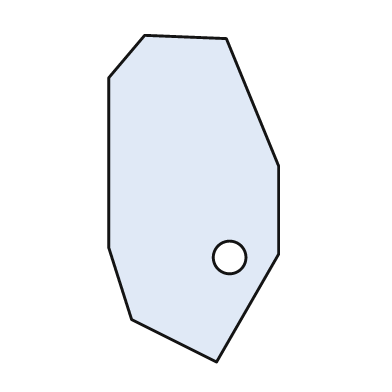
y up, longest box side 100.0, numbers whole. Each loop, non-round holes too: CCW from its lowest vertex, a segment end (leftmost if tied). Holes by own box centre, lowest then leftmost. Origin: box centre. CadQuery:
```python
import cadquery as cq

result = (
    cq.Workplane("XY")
    .moveTo(7.0, -50.0)
    .lineTo(26.0, -17.0)
    .lineTo(26.0, 10.0)
    .lineTo(10.0, 49.0)
    .lineTo(-15.0, 50.0)
    .lineTo(-26.0, 37.0)
    .lineTo(-26.0, -15.0)
    .lineTo(-19.0, -37.0)
    .close()
    .moveTo(11.0, -18.0)
    .circle(5.0)
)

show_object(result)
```